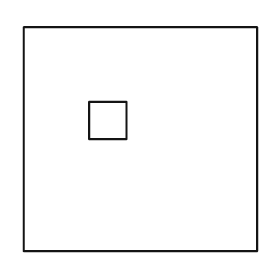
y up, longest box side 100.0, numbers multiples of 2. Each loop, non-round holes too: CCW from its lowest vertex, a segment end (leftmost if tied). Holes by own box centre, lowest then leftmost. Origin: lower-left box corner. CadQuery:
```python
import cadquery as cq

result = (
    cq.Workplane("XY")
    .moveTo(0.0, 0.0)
    .lineTo(100.0, 0.0)
    .lineTo(100.0, 96.0)
    .lineTo(0.0, 96.0)
    .close()
    .moveTo(28.0, 48.0)
    .lineTo(44.0, 48.0)
    .lineTo(44.0, 64.0)
    .lineTo(28.0, 64.0)
    .close()
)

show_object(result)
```